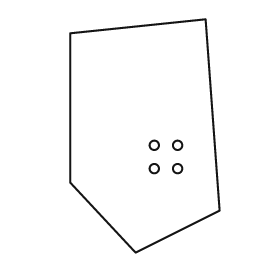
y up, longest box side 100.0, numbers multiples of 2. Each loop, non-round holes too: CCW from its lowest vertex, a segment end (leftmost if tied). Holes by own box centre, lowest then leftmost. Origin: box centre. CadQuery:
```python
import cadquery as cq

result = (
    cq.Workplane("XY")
    .moveTo(-4.0, -50.0)
    .lineTo(32.0, -32.0)
    .lineTo(26.0, 50.0)
    .lineTo(-32.0, 44.0)
    .lineTo(-32.0, -20.0)
    .close()
    .moveTo(4.0, -14.0)
    .circle(2.0)
    .moveTo(14.0, -14.0)
    .circle(2.0)
    .moveTo(4.0, -4.0)
    .circle(2.0)
    .moveTo(14.0, -4.0)
    .circle(2.0)
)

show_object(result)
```